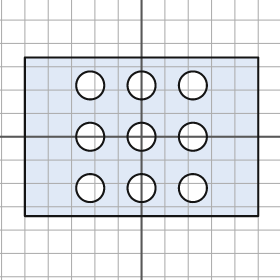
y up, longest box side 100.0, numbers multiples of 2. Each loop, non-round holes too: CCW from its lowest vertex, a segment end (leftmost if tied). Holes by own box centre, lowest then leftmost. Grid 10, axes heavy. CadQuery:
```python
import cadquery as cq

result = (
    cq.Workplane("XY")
    .moveTo(-50.0, -34.0)
    .lineTo(50.0, -34.0)
    .lineTo(50.0, 34.0)
    .lineTo(-50.0, 34.0)
    .close()
    .moveTo(-22.0, -22.0)
    .circle(6.0)
    .moveTo(0.0, -22.0)
    .circle(6.0)
    .moveTo(22.0, -22.0)
    .circle(6.0)
    .moveTo(-22.0, 0.0)
    .circle(6.0)
    .moveTo(0.0, 0.0)
    .circle(6.0)
    .moveTo(22.0, 0.0)
    .circle(6.0)
    .moveTo(-22.0, 22.0)
    .circle(6.0)
    .moveTo(0.0, 22.0)
    .circle(6.0)
    .moveTo(22.0, 22.0)
    .circle(6.0)
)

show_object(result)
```